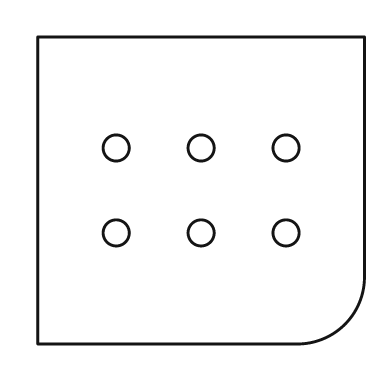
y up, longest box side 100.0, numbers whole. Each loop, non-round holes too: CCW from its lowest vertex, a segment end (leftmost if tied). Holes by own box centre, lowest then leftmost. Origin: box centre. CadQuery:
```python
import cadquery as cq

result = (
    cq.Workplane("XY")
    .moveTo(-50.0, -47.0)
    .lineTo(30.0, -47.0)
    .threePointArc((44.0, -41.0), (50.0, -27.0))
    .lineTo(50.0, 47.0)
    .lineTo(-50.0, 47.0)
    .close()
    .moveTo(-26.0, -13.0)
    .circle(4.0)
    .moveTo(0.0, -13.0)
    .circle(4.0)
    .moveTo(26.0, -13.0)
    .circle(4.0)
    .moveTo(-26.0, 13.0)
    .circle(4.0)
    .moveTo(0.0, 13.0)
    .circle(4.0)
    .moveTo(26.0, 13.0)
    .circle(4.0)
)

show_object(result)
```